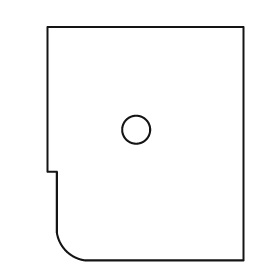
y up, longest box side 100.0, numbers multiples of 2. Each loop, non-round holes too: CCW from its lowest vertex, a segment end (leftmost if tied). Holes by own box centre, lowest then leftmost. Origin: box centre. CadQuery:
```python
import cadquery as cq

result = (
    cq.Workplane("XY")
    .moveTo(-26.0, -50.0)
    .lineTo(42.0, -50.0)
    .lineTo(42.0, 50.0)
    .lineTo(-42.0, 50.0)
    .lineTo(-42.0, -12.0)
    .lineTo(-38.0, -12.0)
    .lineTo(-38.0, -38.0)
    .threePointArc((-34.0, -46.0), (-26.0, -50.0))
    .close()
    .moveTo(-4.0, 6.0)
    .circle(6.0)
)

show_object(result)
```